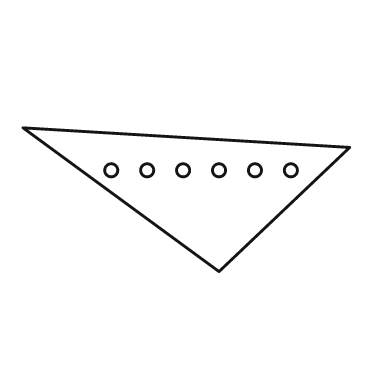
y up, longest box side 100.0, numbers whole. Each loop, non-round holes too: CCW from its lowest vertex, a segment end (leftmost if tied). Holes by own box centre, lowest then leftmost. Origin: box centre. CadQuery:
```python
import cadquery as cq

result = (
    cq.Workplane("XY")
    .moveTo(10.0, -22.0)
    .lineTo(50.0, 16.0)
    .lineTo(-50.0, 22.0)
    .close()
    .moveTo(-23.0, 9.0)
    .circle(2.0)
    .moveTo(-12.0, 9.0)
    .circle(2.0)
    .moveTo(-1.0, 9.0)
    .circle(2.0)
    .moveTo(10.0, 9.0)
    .circle(2.0)
    .moveTo(21.0, 9.0)
    .circle(2.0)
    .moveTo(32.0, 9.0)
    .circle(2.0)
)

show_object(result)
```